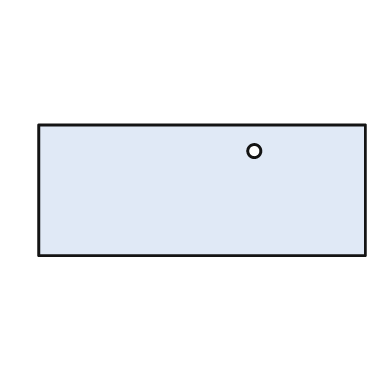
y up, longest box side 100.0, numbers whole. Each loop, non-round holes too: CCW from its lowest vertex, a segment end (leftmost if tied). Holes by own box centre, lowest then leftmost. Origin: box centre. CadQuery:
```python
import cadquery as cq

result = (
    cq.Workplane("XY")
    .moveTo(-50.0, -20.0)
    .lineTo(50.0, -20.0)
    .lineTo(50.0, 20.0)
    .lineTo(-50.0, 20.0)
    .close()
    .moveTo(16.0, 12.0)
    .circle(2.0)
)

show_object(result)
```